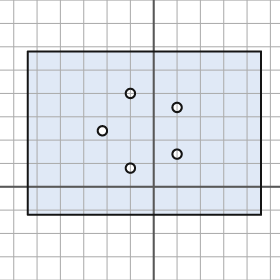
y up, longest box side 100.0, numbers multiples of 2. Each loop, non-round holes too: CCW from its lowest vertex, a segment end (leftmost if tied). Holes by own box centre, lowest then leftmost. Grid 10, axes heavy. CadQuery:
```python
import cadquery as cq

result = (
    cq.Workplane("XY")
    .moveTo(-54.0, -12.0)
    .lineTo(46.0, -12.0)
    .lineTo(46.0, 58.0)
    .lineTo(-54.0, 58.0)
    .close()
    .moveTo(-10.0, 8.0)
    .circle(2.0)
    .moveTo(10.0, 14.0)
    .circle(2.0)
    .moveTo(-22.0, 24.0)
    .circle(2.0)
    .moveTo(10.0, 34.0)
    .circle(2.0)
    .moveTo(-10.0, 40.0)
    .circle(2.0)
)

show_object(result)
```